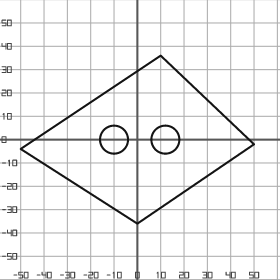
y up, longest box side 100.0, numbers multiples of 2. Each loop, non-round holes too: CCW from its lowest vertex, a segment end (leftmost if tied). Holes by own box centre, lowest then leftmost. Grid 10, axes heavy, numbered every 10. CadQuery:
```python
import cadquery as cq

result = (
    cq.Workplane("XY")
    .moveTo(0.0, -36.0)
    .lineTo(50.0, -2.0)
    .lineTo(10.0, 36.0)
    .lineTo(-50.0, -4.0)
    .close()
    .moveTo(-10.0, 0.0)
    .circle(6.0)
    .moveTo(12.0, 0.0)
    .circle(6.0)
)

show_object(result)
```